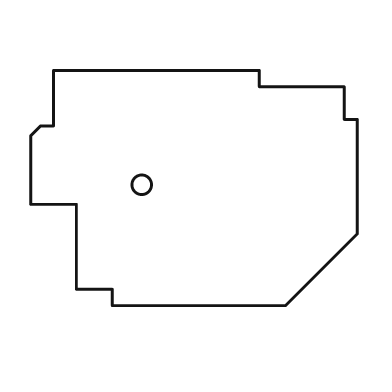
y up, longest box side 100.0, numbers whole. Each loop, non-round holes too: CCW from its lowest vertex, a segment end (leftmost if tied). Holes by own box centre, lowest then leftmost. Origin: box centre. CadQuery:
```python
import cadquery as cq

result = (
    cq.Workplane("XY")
    .moveTo(-25.0, -36.0)
    .lineTo(28.0, -36.0)
    .lineTo(50.0, -14.0)
    .lineTo(50.0, 21.0)
    .lineTo(46.0, 21.0)
    .lineTo(46.0, 31.0)
    .lineTo(20.0, 31.0)
    .lineTo(20.0, 36.0)
    .lineTo(-43.0, 36.0)
    .lineTo(-43.0, 19.0)
    .lineTo(-47.0, 19.0)
    .lineTo(-50.0, 16.0)
    .lineTo(-50.0, -5.0)
    .lineTo(-36.0, -5.0)
    .lineTo(-36.0, -31.0)
    .lineTo(-25.0, -31.0)
    .close()
    .moveTo(-16.0, 1.0)
    .circle(3.0)
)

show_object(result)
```